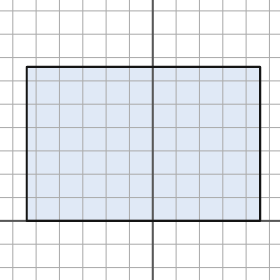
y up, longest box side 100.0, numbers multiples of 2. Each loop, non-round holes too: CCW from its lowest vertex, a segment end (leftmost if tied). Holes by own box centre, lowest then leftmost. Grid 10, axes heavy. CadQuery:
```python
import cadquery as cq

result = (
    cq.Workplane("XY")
    .moveTo(-54.0, 0.0)
    .lineTo(46.0, 0.0)
    .lineTo(46.0, 66.0)
    .lineTo(-54.0, 66.0)
    .close()
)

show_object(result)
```